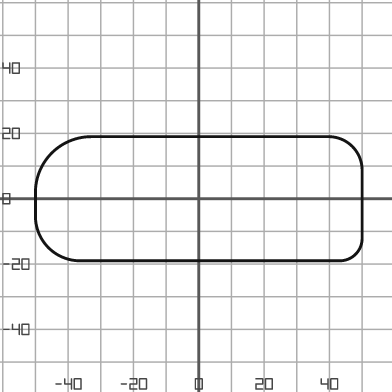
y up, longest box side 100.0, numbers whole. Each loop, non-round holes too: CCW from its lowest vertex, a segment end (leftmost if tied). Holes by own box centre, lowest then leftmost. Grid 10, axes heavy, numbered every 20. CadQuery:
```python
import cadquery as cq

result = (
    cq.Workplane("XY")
    .moveTo(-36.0, -19.0)
    .lineTo(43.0, -19.0)
    .threePointArc((48.0, -17.0), (50.0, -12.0))
    .lineTo(50.0, 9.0)
    .threePointArc((47.0, 16.0), (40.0, 19.0))
    .lineTo(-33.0, 19.0)
    .threePointArc((-45.0, 14.0), (-50.0, 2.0))
    .lineTo(-50.0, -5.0)
    .threePointArc((-46.0, -15.0), (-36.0, -19.0))
    .close()
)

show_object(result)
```